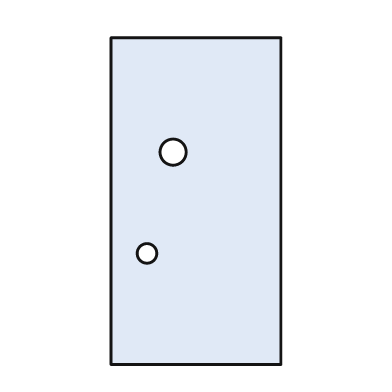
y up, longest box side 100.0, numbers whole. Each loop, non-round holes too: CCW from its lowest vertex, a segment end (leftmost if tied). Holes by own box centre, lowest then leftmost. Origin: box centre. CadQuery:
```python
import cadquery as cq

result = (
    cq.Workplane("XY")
    .moveTo(-26.0, -50.0)
    .lineTo(26.0, -50.0)
    .lineTo(26.0, 50.0)
    .lineTo(-26.0, 50.0)
    .close()
    .moveTo(-15.0, -16.0)
    .circle(3.0)
    .moveTo(-7.0, 15.0)
    .circle(4.0)
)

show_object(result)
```